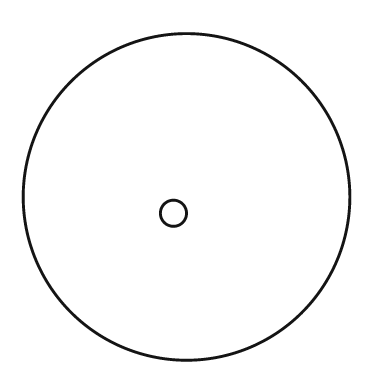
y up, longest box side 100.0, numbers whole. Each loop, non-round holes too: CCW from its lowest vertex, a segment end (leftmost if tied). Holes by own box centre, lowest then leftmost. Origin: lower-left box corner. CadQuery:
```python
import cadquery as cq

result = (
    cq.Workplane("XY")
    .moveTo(50.0, 50.0)
    .circle(50.0)
    .moveTo(46.0, 45.0)
    .circle(4.0)
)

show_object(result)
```